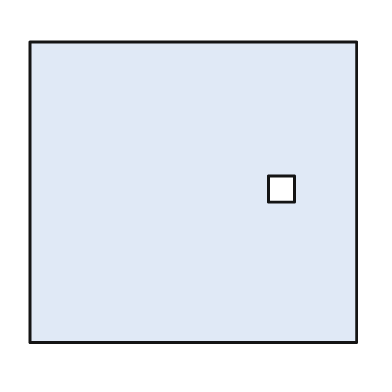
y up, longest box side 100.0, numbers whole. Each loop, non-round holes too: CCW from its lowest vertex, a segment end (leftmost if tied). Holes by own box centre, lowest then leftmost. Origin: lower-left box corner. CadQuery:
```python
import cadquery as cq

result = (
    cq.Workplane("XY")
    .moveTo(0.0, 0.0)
    .lineTo(100.0, 0.0)
    .lineTo(100.0, 92.0)
    .lineTo(0.0, 92.0)
    .close()
    .moveTo(73.0, 43.0)
    .lineTo(81.0, 43.0)
    .lineTo(81.0, 51.0)
    .lineTo(73.0, 51.0)
    .close()
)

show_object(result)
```